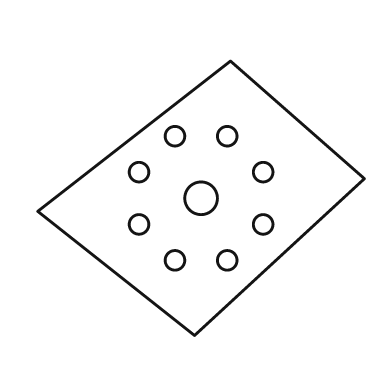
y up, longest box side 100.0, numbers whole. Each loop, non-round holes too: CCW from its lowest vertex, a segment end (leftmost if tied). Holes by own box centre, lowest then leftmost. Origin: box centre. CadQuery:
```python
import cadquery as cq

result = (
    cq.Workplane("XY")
    .moveTo(-2.0, -42.0)
    .lineTo(50.0, 6.0)
    .lineTo(9.0, 42.0)
    .lineTo(-50.0, -4.0)
    .close()
    .moveTo(-8.0, -19.0)
    .circle(3.0)
    .moveTo(8.0, -19.0)
    .circle(3.0)
    .moveTo(-19.0, -8.0)
    .circle(3.0)
    .moveTo(19.0, -8.0)
    .circle(3.0)
    .moveTo(0.0, 0.0)
    .circle(5.0)
    .moveTo(-19.0, 8.0)
    .circle(3.0)
    .moveTo(19.0, 8.0)
    .circle(3.0)
    .moveTo(-8.0, 19.0)
    .circle(3.0)
    .moveTo(8.0, 19.0)
    .circle(3.0)
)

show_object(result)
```